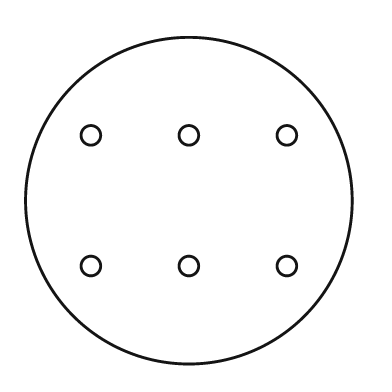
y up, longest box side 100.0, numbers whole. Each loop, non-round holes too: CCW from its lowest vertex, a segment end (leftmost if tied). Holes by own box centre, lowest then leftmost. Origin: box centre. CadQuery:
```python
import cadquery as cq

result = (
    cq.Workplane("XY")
    .moveTo(0.0, 0.0)
    .circle(50.0)
    .moveTo(-30.0, -20.0)
    .circle(3.0)
    .moveTo(0.0, -20.0)
    .circle(3.0)
    .moveTo(30.0, -20.0)
    .circle(3.0)
    .moveTo(-30.0, 20.0)
    .circle(3.0)
    .moveTo(0.0, 20.0)
    .circle(3.0)
    .moveTo(30.0, 20.0)
    .circle(3.0)
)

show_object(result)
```